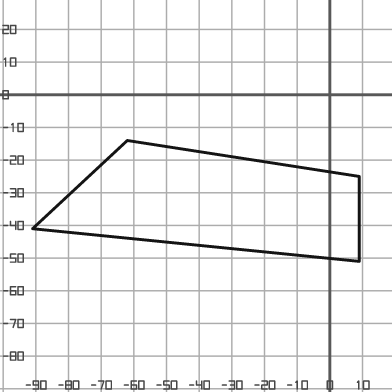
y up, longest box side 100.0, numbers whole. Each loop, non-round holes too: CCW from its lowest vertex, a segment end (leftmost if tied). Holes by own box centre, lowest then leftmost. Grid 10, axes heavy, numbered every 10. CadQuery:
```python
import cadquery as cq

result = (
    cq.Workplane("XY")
    .moveTo(9.0, -51.0)
    .lineTo(9.0, -25.0)
    .lineTo(-62.0, -14.0)
    .lineTo(-91.0, -41.0)
    .close()
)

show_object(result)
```